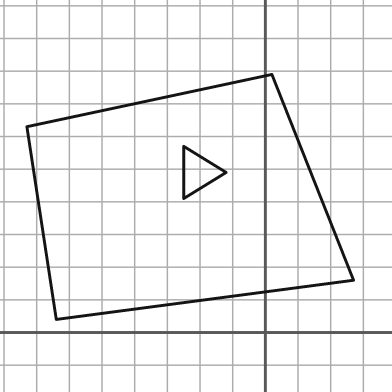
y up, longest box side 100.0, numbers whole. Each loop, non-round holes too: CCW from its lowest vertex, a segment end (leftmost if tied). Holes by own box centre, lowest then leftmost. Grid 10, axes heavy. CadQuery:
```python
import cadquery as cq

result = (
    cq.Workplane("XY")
    .moveTo(-64.0, 4.0)
    .lineTo(27.0, 16.0)
    .lineTo(2.0, 79.0)
    .lineTo(-73.0, 63.0)
    .close()
    .moveTo(-25.0, 41.0)
    .lineTo(-12.0, 49.0)
    .lineTo(-25.0, 57.0)
    .close()
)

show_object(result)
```